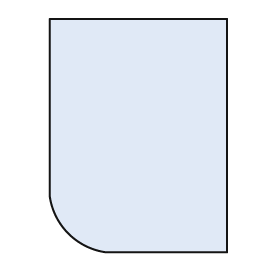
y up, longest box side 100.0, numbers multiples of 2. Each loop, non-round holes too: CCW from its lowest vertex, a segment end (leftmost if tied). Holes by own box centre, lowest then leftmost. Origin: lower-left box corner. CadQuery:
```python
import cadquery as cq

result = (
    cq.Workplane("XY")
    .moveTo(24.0, 0.0)
    .lineTo(76.0, 0.0)
    .lineTo(76.0, 100.0)
    .lineTo(0.0, 100.0)
    .lineTo(0.0, 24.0)
    .threePointArc((8.0, 8.0), (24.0, 0.0))
    .close()
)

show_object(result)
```